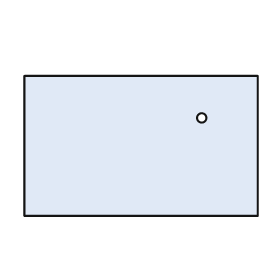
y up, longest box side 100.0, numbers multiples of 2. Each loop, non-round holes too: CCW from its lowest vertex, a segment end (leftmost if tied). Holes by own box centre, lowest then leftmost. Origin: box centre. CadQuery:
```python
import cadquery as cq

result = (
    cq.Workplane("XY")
    .moveTo(-50.0, -30.0)
    .lineTo(50.0, -30.0)
    .lineTo(50.0, 30.0)
    .lineTo(-50.0, 30.0)
    .close()
    .moveTo(26.0, 12.0)
    .circle(2.0)
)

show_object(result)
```